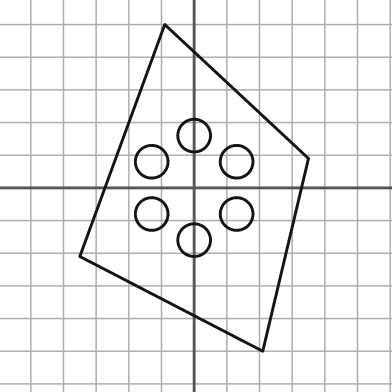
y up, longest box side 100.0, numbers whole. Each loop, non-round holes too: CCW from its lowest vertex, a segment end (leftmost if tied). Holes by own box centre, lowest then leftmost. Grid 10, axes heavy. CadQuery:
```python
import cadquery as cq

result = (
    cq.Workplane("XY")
    .moveTo(21.0, -50.0)
    .lineTo(35.0, 9.0)
    .lineTo(-9.0, 50.0)
    .lineTo(-35.0, -21.0)
    .close()
    .moveTo(0.0, -16.0)
    .circle(5.0)
    .moveTo(-13.0, -8.0)
    .circle(5.0)
    .moveTo(13.0, -8.0)
    .circle(5.0)
    .moveTo(-13.0, 8.0)
    .circle(5.0)
    .moveTo(13.0, 8.0)
    .circle(5.0)
    .moveTo(0.0, 16.0)
    .circle(5.0)
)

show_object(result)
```